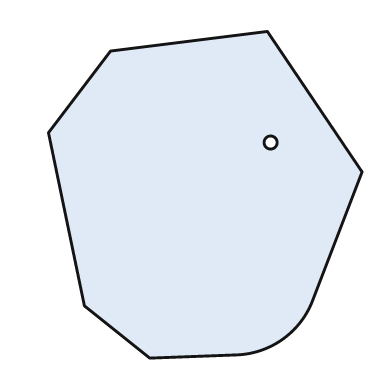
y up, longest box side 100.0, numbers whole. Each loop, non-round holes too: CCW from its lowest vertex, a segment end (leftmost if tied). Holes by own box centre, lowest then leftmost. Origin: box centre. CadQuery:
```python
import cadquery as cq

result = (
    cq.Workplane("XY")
    .moveTo(-17.0, -50.0)
    .lineTo(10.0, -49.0)
    .threePointArc((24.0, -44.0), (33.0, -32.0))
    .lineTo(48.0, 7.0)
    .lineTo(19.0, 50.0)
    .lineTo(-29.0, 44.0)
    .lineTo(-48.0, 19.0)
    .lineTo(-37.0, -34.0)
    .close()
    .moveTo(20.0, 16.0)
    .circle(2.0)
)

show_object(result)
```